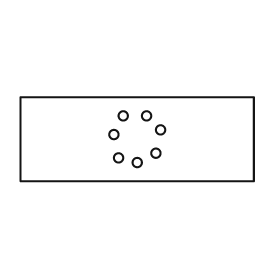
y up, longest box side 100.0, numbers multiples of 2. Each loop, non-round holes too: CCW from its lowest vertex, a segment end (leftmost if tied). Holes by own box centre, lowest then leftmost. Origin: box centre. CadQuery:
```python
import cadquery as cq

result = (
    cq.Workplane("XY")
    .moveTo(-50.0, -18.0)
    .lineTo(50.0, -18.0)
    .lineTo(50.0, 18.0)
    .lineTo(-50.0, 18.0)
    .close()
    .moveTo(0.0, -10.0)
    .circle(2.0)
    .moveTo(-8.0, -8.0)
    .circle(2.0)
    .moveTo(8.0, -6.0)
    .circle(2.0)
    .moveTo(-10.0, 2.0)
    .circle(2.0)
    .moveTo(10.0, 4.0)
    .circle(2.0)
    .moveTo(-6.0, 10.0)
    .circle(2.0)
    .moveTo(4.0, 10.0)
    .circle(2.0)
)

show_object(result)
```